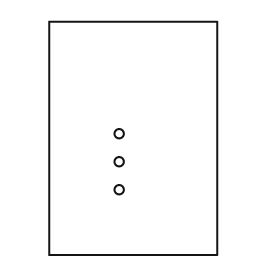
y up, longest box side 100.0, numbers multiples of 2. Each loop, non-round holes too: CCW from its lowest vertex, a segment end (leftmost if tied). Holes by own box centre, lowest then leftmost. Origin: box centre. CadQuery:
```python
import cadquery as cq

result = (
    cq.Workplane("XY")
    .moveTo(-36.0, -50.0)
    .lineTo(36.0, -50.0)
    .lineTo(36.0, 50.0)
    .lineTo(-36.0, 50.0)
    .close()
    .moveTo(-6.0, -22.0)
    .circle(2.0)
    .moveTo(-6.0, -10.0)
    .circle(2.0)
    .moveTo(-6.0, 2.0)
    .circle(2.0)
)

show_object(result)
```